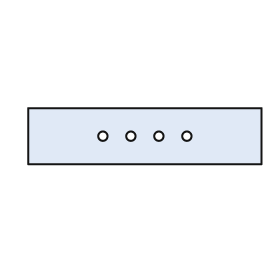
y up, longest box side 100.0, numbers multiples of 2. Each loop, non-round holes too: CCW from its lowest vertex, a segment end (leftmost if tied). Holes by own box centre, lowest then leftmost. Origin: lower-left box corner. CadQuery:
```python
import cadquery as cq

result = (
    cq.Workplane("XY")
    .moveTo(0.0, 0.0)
    .lineTo(100.0, 0.0)
    .lineTo(100.0, 24.0)
    .lineTo(0.0, 24.0)
    .close()
    .moveTo(32.0, 12.0)
    .circle(2.0)
    .moveTo(44.0, 12.0)
    .circle(2.0)
    .moveTo(56.0, 12.0)
    .circle(2.0)
    .moveTo(68.0, 12.0)
    .circle(2.0)
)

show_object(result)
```